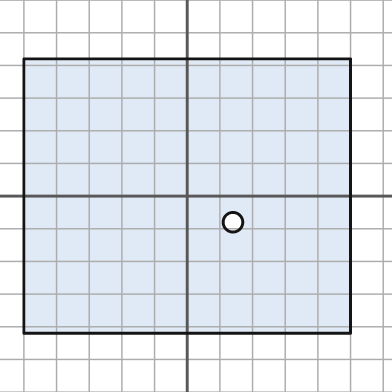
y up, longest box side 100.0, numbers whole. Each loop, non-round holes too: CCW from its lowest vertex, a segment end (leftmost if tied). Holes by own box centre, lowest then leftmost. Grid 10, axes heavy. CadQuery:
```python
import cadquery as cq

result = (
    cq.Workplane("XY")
    .moveTo(-50.0, -42.0)
    .lineTo(50.0, -42.0)
    .lineTo(50.0, 42.0)
    .lineTo(-50.0, 42.0)
    .close()
    .moveTo(14.0, -8.0)
    .circle(3.0)
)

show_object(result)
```